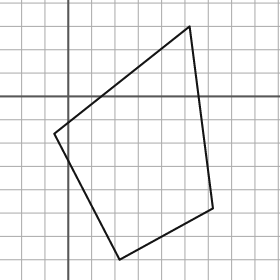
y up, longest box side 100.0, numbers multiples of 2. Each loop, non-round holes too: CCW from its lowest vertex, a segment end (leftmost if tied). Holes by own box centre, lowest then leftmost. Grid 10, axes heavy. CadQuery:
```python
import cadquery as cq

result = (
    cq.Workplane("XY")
    .moveTo(22.0, -70.0)
    .lineTo(62.0, -48.0)
    .lineTo(52.0, 30.0)
    .lineTo(-6.0, -16.0)
    .close()
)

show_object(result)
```